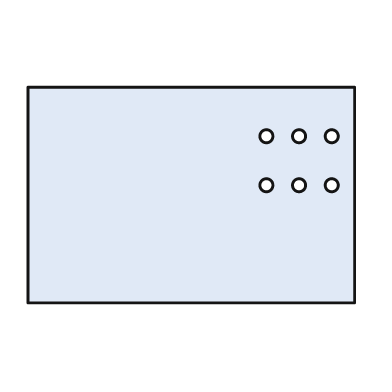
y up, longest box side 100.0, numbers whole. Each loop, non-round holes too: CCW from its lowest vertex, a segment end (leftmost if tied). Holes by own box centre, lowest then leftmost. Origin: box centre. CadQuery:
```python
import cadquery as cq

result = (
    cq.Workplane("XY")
    .moveTo(-50.0, -33.0)
    .lineTo(50.0, -33.0)
    .lineTo(50.0, 33.0)
    .lineTo(-50.0, 33.0)
    .close()
    .moveTo(23.0, 3.0)
    .circle(2.0)
    .moveTo(33.0, 3.0)
    .circle(2.0)
    .moveTo(43.0, 3.0)
    .circle(2.0)
    .moveTo(23.0, 18.0)
    .circle(2.0)
    .moveTo(33.0, 18.0)
    .circle(2.0)
    .moveTo(43.0, 18.0)
    .circle(2.0)
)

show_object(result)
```